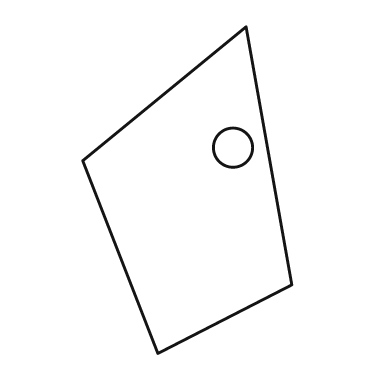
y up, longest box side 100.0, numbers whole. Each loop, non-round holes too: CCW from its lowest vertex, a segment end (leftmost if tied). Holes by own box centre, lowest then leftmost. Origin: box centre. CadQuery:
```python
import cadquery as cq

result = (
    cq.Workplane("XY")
    .moveTo(-9.0, -50.0)
    .lineTo(32.0, -29.0)
    .lineTo(18.0, 50.0)
    .lineTo(-32.0, 9.0)
    .close()
    .moveTo(14.0, 13.0)
    .circle(6.0)
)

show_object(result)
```